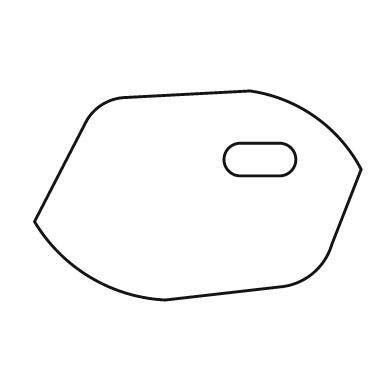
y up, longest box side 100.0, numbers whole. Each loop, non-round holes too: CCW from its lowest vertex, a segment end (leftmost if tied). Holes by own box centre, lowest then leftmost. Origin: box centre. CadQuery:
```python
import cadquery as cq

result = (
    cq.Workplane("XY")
    .moveTo(-10.0, -32.0)
    .lineTo(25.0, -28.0)
    .threePointArc((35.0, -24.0), (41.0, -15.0))
    .lineTo(50.0, 8.0)
    .threePointArc((36.0, 24.0), (16.0, 32.0))
    .lineTo(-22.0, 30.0)
    .threePointArc((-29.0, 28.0), (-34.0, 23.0))
    .lineTo(-50.0, -8.0)
    .threePointArc((-33.0, -25.0), (-10.0, -32.0))
    .close()
    .moveTo(13.0, 6.0)
    .lineTo(25.0, 6.0)
    .threePointArc((30.0, 11.0), (25.0, 16.0))
    .lineTo(13.0, 16.0)
    .threePointArc((8.0, 11.0), (13.0, 6.0))
    .close()
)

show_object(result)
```